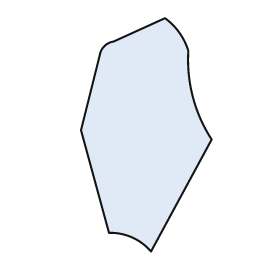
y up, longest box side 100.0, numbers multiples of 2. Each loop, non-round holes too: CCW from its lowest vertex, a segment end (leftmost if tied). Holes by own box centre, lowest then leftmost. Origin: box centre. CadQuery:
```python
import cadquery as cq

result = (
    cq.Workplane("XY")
    .moveTo(2.0, -50.0)
    .lineTo(28.0, -2.0)
    .threePointArc((20.0, 16.0), (18.0, 36.0))
    .threePointArc((14.0, 44.0), (8.0, 50.0))
    .lineTo(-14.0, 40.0)
    .threePointArc((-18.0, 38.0), (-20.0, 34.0))
    .lineTo(-28.0, 2.0)
    .lineTo(-16.0, -42.0)
    .threePointArc((-6.0, -44.0), (2.0, -50.0))
    .close()
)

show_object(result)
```